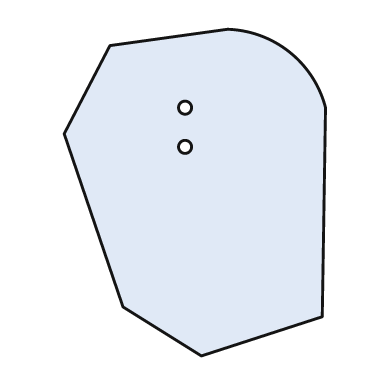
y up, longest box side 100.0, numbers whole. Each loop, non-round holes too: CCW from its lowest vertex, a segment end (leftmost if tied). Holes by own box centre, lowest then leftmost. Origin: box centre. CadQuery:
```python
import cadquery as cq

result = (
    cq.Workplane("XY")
    .moveTo(2.0, -50.0)
    .lineTo(39.0, -38.0)
    .lineTo(40.0, 26.0)
    .threePointArc((29.0, 43.0), (10.0, 50.0))
    .lineTo(-26.0, 45.0)
    .lineTo(-40.0, 18.0)
    .lineTo(-22.0, -35.0)
    .close()
    .moveTo(-3.0, 14.0)
    .circle(2.0)
    .moveTo(-3.0, 26.0)
    .circle(2.0)
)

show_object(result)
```